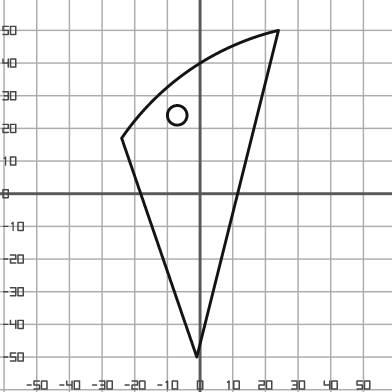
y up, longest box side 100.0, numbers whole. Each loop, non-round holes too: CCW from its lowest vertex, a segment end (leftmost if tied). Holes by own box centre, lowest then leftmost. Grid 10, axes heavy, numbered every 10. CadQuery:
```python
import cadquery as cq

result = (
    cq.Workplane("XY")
    .moveTo(-1.0, -50.0)
    .lineTo(24.0, 50.0)
    .threePointArc((-3.0, 38.0), (-24.0, 17.0))
    .close()
    .moveTo(-7.0, 24.0)
    .circle(3.0)
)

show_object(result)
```